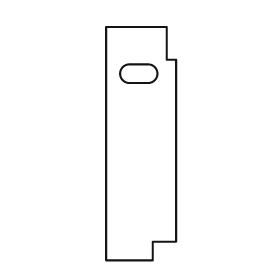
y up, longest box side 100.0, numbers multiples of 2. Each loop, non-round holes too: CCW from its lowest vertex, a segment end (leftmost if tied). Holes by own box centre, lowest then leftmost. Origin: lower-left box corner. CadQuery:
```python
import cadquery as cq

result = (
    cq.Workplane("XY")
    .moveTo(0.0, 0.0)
    .lineTo(20.0, 0.0)
    .lineTo(20.0, 8.0)
    .lineTo(30.0, 8.0)
    .lineTo(30.0, 86.0)
    .lineTo(26.0, 86.0)
    .lineTo(26.0, 100.0)
    .lineTo(0.0, 100.0)
    .close()
    .moveTo(10.0, 76.0)
    .lineTo(18.0, 76.0)
    .threePointArc((22.0, 80.0), (18.0, 84.0))
    .lineTo(10.0, 84.0)
    .threePointArc((6.0, 80.0), (10.0, 76.0))
    .close()
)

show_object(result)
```